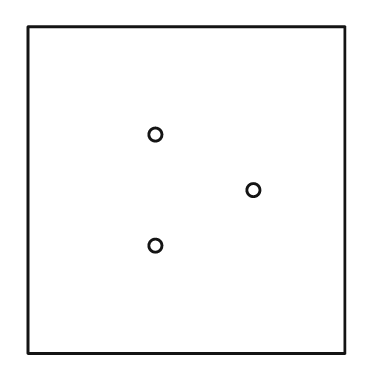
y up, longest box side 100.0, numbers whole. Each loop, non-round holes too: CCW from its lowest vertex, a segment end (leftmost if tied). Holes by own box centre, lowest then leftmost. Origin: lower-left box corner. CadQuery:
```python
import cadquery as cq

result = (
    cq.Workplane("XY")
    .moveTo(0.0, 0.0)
    .lineTo(97.0, 0.0)
    .lineTo(97.0, 100.0)
    .lineTo(0.0, 100.0)
    .close()
    .moveTo(39.0, 33.0)
    .circle(2.0)
    .moveTo(69.0, 50.0)
    .circle(2.0)
    .moveTo(39.0, 67.0)
    .circle(2.0)
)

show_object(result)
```